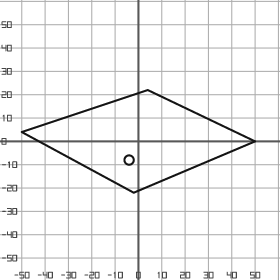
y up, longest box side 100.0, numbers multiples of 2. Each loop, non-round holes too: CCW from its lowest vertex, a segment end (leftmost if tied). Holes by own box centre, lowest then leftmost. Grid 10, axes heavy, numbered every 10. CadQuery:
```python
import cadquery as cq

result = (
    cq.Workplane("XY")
    .moveTo(-2.0, -22.0)
    .lineTo(50.0, 0.0)
    .lineTo(4.0, 22.0)
    .lineTo(-50.0, 4.0)
    .close()
    .moveTo(-4.0, -8.0)
    .circle(2.0)
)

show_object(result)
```